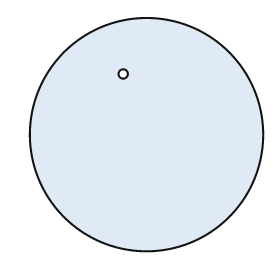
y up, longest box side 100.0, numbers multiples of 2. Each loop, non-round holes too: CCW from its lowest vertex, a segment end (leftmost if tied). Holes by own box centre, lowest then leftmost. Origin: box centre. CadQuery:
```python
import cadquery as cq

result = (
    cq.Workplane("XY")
    .moveTo(0.0, 0.0)
    .circle(50.0)
    .moveTo(-10.0, 26.0)
    .circle(2.0)
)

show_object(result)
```